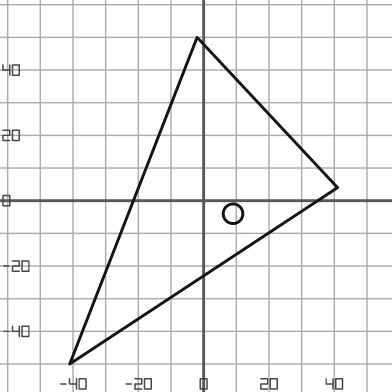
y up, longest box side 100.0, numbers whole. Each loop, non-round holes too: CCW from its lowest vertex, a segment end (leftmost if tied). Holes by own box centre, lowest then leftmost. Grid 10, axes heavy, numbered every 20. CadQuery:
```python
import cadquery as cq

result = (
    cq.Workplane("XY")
    .moveTo(-41.0, -50.0)
    .lineTo(41.0, 4.0)
    .lineTo(-2.0, 50.0)
    .close()
    .moveTo(9.0, -4.0)
    .circle(3.0)
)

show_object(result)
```